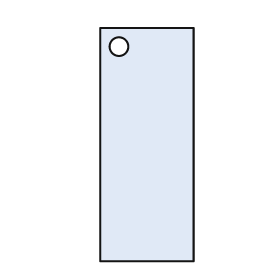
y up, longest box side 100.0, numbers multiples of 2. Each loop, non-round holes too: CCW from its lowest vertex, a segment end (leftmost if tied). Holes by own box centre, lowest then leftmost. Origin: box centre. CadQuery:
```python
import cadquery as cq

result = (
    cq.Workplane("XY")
    .moveTo(-20.0, -50.0)
    .lineTo(20.0, -50.0)
    .lineTo(20.0, 50.0)
    .lineTo(-20.0, 50.0)
    .close()
    .moveTo(-12.0, 42.0)
    .circle(4.0)
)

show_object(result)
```